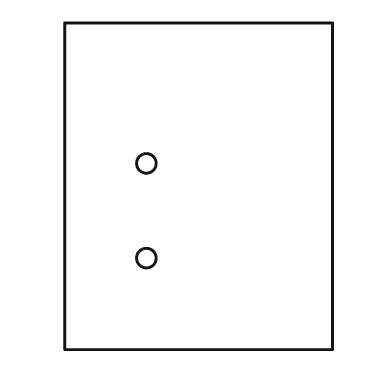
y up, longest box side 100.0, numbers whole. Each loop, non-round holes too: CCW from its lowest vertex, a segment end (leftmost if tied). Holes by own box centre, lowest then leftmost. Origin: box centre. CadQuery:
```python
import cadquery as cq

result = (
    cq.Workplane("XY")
    .moveTo(-41.0, -50.0)
    .lineTo(41.0, -50.0)
    .lineTo(41.0, 50.0)
    .lineTo(-41.0, 50.0)
    .close()
    .moveTo(-16.0, -22.0)
    .circle(3.0)
    .moveTo(-16.0, 7.0)
    .circle(3.0)
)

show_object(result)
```